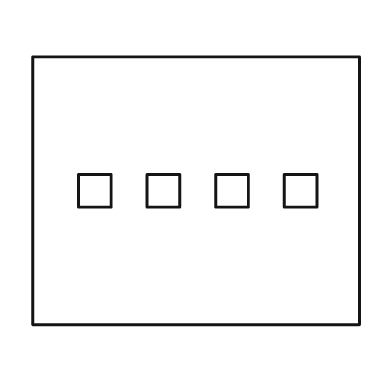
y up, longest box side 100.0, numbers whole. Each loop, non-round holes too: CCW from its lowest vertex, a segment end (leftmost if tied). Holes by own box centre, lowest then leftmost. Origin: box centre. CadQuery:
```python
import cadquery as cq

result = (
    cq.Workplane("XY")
    .moveTo(-50.0, -41.0)
    .lineTo(50.0, -41.0)
    .lineTo(50.0, 41.0)
    .lineTo(-50.0, 41.0)
    .close()
    .moveTo(-36.0, -5.0)
    .lineTo(-26.0, -5.0)
    .lineTo(-26.0, 5.0)
    .lineTo(-36.0, 5.0)
    .close()
    .moveTo(-15.0, -5.0)
    .lineTo(-5.0, -5.0)
    .lineTo(-5.0, 5.0)
    .lineTo(-15.0, 5.0)
    .close()
    .moveTo(6.0, -5.0)
    .lineTo(16.0, -5.0)
    .lineTo(16.0, 5.0)
    .lineTo(6.0, 5.0)
    .close()
    .moveTo(27.0, -5.0)
    .lineTo(37.0, -5.0)
    .lineTo(37.0, 5.0)
    .lineTo(27.0, 5.0)
    .close()
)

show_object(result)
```